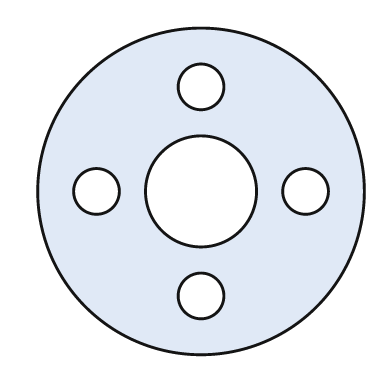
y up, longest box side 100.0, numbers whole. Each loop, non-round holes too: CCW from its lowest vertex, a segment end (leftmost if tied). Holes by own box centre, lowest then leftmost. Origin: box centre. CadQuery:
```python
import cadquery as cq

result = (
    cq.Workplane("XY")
    .moveTo(0.0, 0.0)
    .circle(50.0)
    .moveTo(0.0, -32.0)
    .circle(7.0)
    .moveTo(-32.0, 0.0)
    .circle(7.0)
    .moveTo(0.0, 0.0)
    .circle(17.0)
    .moveTo(32.0, 0.0)
    .circle(7.0)
    .moveTo(0.0, 32.0)
    .circle(7.0)
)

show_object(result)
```